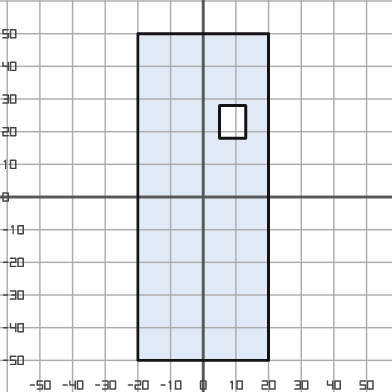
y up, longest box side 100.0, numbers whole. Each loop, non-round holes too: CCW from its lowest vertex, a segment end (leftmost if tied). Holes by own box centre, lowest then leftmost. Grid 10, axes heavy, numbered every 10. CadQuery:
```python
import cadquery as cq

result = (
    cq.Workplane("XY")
    .moveTo(-20.0, -50.0)
    .lineTo(20.0, -50.0)
    .lineTo(20.0, 50.0)
    .lineTo(-20.0, 50.0)
    .close()
    .moveTo(5.0, 18.0)
    .lineTo(13.0, 18.0)
    .lineTo(13.0, 28.0)
    .lineTo(5.0, 28.0)
    .close()
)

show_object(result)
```